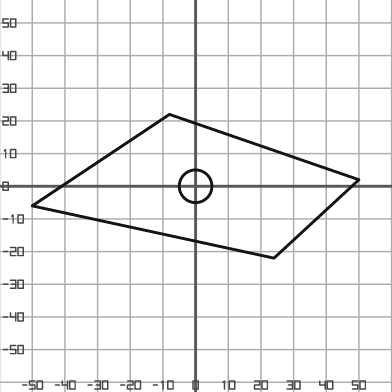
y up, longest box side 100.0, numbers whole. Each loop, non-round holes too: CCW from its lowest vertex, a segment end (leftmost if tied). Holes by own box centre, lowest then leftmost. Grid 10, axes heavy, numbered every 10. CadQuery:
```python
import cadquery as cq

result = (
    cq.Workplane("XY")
    .moveTo(24.0, -22.0)
    .lineTo(50.0, 2.0)
    .lineTo(-8.0, 22.0)
    .lineTo(-50.0, -6.0)
    .close()
    .moveTo(0.0, 0.0)
    .circle(5.0)
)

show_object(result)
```